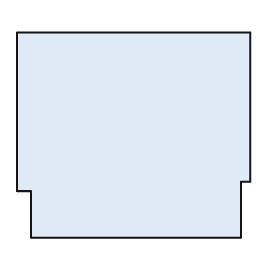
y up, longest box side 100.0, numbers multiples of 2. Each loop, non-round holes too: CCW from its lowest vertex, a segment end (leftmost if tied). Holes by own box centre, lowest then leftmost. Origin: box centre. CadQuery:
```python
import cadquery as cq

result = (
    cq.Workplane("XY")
    .moveTo(-44.0, -44.0)
    .lineTo(46.0, -44.0)
    .lineTo(46.0, -20.0)
    .lineTo(50.0, -20.0)
    .lineTo(50.0, 44.0)
    .lineTo(-50.0, 44.0)
    .lineTo(-50.0, -24.0)
    .lineTo(-44.0, -24.0)
    .close()
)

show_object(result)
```